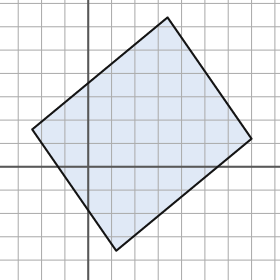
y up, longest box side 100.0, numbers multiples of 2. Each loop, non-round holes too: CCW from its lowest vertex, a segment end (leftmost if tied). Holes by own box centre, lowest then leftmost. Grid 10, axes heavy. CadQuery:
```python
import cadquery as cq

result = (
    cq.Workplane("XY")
    .moveTo(12.0, -36.0)
    .lineTo(70.0, 12.0)
    .lineTo(34.0, 64.0)
    .lineTo(-24.0, 16.0)
    .close()
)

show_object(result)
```